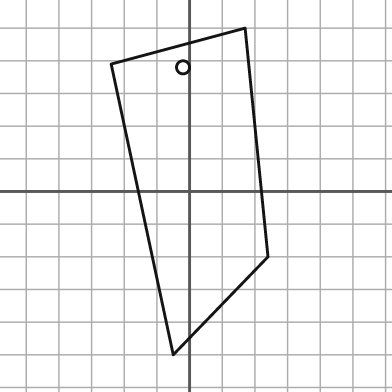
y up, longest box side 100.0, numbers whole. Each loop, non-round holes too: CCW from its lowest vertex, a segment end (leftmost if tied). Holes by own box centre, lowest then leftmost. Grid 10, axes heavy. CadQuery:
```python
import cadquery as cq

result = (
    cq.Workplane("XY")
    .moveTo(-5.0, -50.0)
    .lineTo(24.0, -20.0)
    .lineTo(17.0, 50.0)
    .lineTo(-24.0, 39.0)
    .close()
    .moveTo(-2.0, 38.0)
    .circle(2.0)
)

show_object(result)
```